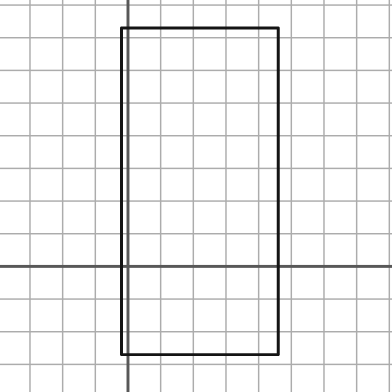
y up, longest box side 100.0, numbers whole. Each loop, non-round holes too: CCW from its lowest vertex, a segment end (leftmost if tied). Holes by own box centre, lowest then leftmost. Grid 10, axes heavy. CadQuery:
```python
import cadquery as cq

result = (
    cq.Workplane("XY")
    .moveTo(-2.0, -27.0)
    .lineTo(46.0, -27.0)
    .lineTo(46.0, 73.0)
    .lineTo(-2.0, 73.0)
    .close()
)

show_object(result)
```